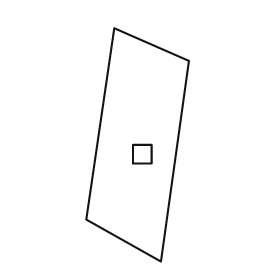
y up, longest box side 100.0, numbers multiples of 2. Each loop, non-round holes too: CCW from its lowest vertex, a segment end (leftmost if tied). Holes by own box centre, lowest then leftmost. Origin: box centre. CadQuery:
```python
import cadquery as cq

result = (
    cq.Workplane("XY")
    .moveTo(10.0, -50.0)
    .lineTo(22.0, 36.0)
    .lineTo(-10.0, 50.0)
    .lineTo(-22.0, -32.0)
    .close()
    .moveTo(-2.0, -8.0)
    .lineTo(6.0, -8.0)
    .lineTo(6.0, 0.0)
    .lineTo(-2.0, 0.0)
    .close()
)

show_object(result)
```